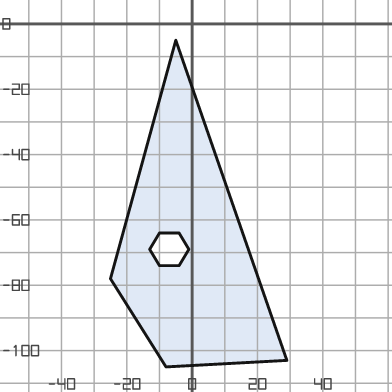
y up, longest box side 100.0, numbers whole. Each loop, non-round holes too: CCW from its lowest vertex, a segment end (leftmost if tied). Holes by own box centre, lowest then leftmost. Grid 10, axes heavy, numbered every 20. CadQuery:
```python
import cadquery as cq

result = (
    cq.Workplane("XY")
    .moveTo(-8.0, -105.0)
    .lineTo(29.0, -103.0)
    .lineTo(-5.0, -5.0)
    .lineTo(-25.0, -78.0)
    .close()
    .moveTo(-10.0, -74.0)
    .lineTo(-4.0, -74.0)
    .lineTo(-1.0, -69.0)
    .lineTo(-4.0, -64.0)
    .lineTo(-10.0, -64.0)
    .lineTo(-13.0, -69.0)
    .close()
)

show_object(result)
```